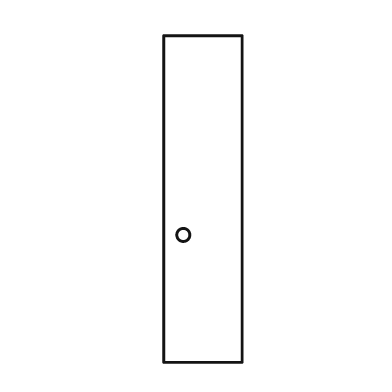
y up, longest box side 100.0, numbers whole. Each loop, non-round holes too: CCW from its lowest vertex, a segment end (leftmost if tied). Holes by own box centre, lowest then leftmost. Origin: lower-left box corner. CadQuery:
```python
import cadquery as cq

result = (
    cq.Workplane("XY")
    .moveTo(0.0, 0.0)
    .lineTo(24.0, 0.0)
    .lineTo(24.0, 100.0)
    .lineTo(0.0, 100.0)
    .close()
    .moveTo(6.0, 39.0)
    .circle(2.0)
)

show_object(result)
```